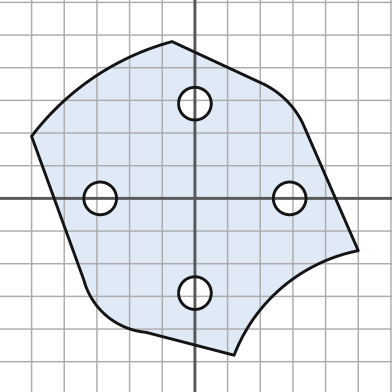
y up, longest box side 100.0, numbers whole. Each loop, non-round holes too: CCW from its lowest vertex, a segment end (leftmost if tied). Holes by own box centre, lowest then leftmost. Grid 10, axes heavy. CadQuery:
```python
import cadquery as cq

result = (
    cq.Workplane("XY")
    .moveTo(12.0, -48.0)
    .threePointArc((27.0, -27.0), (50.0, -16.0))
    .lineTo(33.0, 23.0)
    .threePointArc((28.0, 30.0), (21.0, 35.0))
    .lineTo(-7.0, 48.0)
    .threePointArc((-31.0, 37.0), (-50.0, 19.0))
    .lineTo(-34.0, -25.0)
    .threePointArc((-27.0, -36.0), (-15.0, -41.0))
    .close()
    .moveTo(0.0, -29.0)
    .circle(5.0)
    .moveTo(-29.0, 0.0)
    .circle(5.0)
    .moveTo(29.0, 0.0)
    .circle(5.0)
    .moveTo(0.0, 29.0)
    .circle(5.0)
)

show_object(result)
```